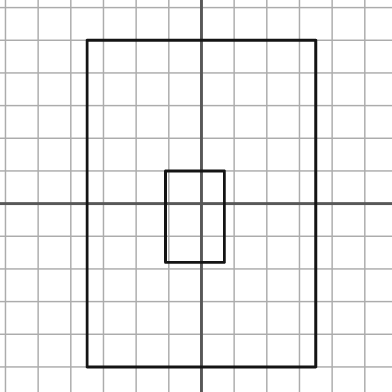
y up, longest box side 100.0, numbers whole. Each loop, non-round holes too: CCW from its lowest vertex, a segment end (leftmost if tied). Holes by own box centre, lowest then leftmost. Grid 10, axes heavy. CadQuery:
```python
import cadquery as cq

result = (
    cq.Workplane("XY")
    .moveTo(-35.0, -50.0)
    .lineTo(35.0, -50.0)
    .lineTo(35.0, 50.0)
    .lineTo(-35.0, 50.0)
    .close()
    .moveTo(-11.0, -18.0)
    .lineTo(7.0, -18.0)
    .lineTo(7.0, 10.0)
    .lineTo(-11.0, 10.0)
    .close()
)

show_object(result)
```